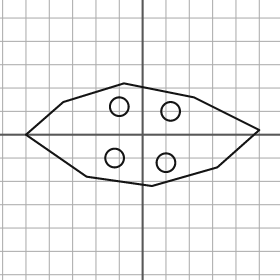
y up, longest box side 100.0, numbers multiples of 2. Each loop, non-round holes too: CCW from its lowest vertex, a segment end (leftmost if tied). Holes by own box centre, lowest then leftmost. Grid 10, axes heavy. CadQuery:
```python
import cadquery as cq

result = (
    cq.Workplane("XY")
    .moveTo(4.0, -22.0)
    .lineTo(32.0, -14.0)
    .lineTo(50.0, 2.0)
    .lineTo(22.0, 16.0)
    .lineTo(-8.0, 22.0)
    .lineTo(-34.0, 14.0)
    .lineTo(-50.0, 0.0)
    .lineTo(-24.0, -18.0)
    .close()
    .moveTo(10.0, -12.0)
    .circle(4.0)
    .moveTo(-12.0, -10.0)
    .circle(4.0)
    .moveTo(12.0, 10.0)
    .circle(4.0)
    .moveTo(-10.0, 12.0)
    .circle(4.0)
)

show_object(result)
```